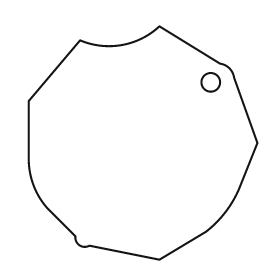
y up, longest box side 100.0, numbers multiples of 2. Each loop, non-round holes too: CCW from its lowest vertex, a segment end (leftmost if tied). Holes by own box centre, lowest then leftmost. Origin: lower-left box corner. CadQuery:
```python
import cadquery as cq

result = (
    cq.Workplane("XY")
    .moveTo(56.0, 0.0)
    .lineTo(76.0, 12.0)
    .threePointArc((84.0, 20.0), (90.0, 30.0))
    .lineTo(98.0, 50.0)
    .lineTo(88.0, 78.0)
    .threePointArc((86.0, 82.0), (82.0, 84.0))
    .lineTo(56.0, 100.0)
    .threePointArc((40.0, 92.0), (22.0, 94.0))
    .lineTo(0.0, 68.0)
    .lineTo(0.0, 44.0)
    .threePointArc((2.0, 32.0), (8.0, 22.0))
    .lineTo(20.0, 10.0)
    .threePointArc((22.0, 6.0), (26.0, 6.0))
    .close()
    .moveTo(78.0, 76.0)
    .circle(4.0)
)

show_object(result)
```